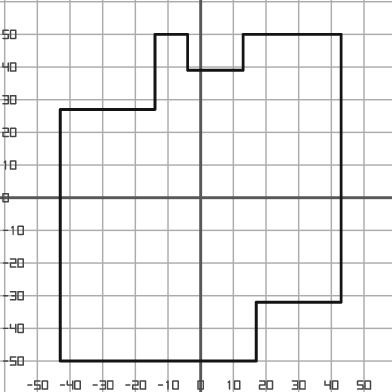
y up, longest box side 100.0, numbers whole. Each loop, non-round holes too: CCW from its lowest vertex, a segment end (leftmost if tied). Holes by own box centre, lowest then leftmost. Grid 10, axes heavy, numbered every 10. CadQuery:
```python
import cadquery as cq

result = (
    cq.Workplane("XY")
    .moveTo(-43.0, -50.0)
    .lineTo(17.0, -50.0)
    .lineTo(17.0, -32.0)
    .lineTo(43.0, -32.0)
    .lineTo(43.0, 50.0)
    .lineTo(13.0, 50.0)
    .lineTo(13.0, 39.0)
    .lineTo(-4.0, 39.0)
    .lineTo(-4.0, 50.0)
    .lineTo(-14.0, 50.0)
    .lineTo(-14.0, 27.0)
    .lineTo(-43.0, 27.0)
    .close()
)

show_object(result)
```